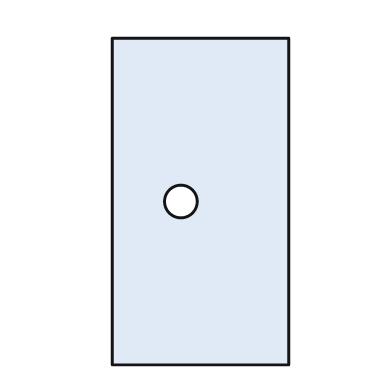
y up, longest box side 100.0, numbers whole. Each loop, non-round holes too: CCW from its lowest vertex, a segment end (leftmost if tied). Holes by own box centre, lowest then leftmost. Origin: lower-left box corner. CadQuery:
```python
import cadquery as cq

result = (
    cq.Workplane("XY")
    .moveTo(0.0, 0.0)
    .lineTo(54.0, 0.0)
    .lineTo(54.0, 100.0)
    .lineTo(0.0, 100.0)
    .close()
    .moveTo(21.0, 50.0)
    .circle(5.0)
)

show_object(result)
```